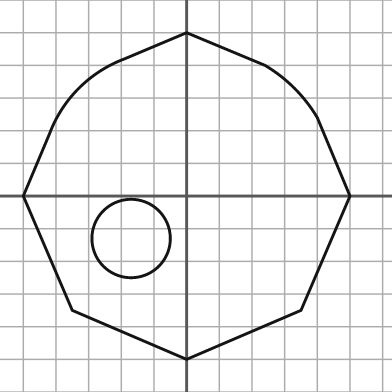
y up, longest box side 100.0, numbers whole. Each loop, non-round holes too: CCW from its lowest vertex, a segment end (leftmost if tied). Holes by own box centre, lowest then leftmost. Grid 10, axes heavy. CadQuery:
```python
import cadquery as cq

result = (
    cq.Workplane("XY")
    .moveTo(0.0, -50.0)
    .lineTo(35.0, -35.0)
    .lineTo(50.0, 0.0)
    .lineTo(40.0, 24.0)
    .threePointArc((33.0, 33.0), (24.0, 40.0))
    .lineTo(0.0, 50.0)
    .lineTo(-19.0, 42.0)
    .threePointArc((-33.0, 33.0), (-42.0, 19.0))
    .lineTo(-50.0, 0.0)
    .lineTo(-35.0, -35.0)
    .close()
    .moveTo(-17.0, -13.0)
    .circle(12.0)
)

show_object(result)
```